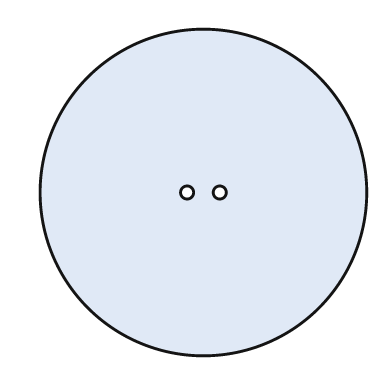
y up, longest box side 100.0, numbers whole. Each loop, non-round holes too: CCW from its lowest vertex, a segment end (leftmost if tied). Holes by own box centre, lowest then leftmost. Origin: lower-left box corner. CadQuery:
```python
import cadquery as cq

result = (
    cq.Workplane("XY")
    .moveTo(50.0, 50.0)
    .circle(50.0)
    .moveTo(45.0, 50.0)
    .circle(2.0)
    .moveTo(55.0, 50.0)
    .circle(2.0)
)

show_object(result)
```